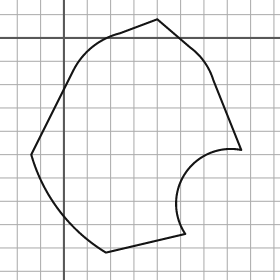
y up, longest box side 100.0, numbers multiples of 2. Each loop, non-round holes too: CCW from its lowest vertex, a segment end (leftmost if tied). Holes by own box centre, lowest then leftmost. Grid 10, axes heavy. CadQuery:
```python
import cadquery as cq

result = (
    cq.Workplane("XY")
    .moveTo(18.0, -92.0)
    .lineTo(52.0, -84.0)
    .threePointArc((52.0, -58.0), (76.0, -48.0))
    .lineTo(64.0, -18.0)
    .threePointArc((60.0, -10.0), (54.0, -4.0))
    .lineTo(40.0, 8.0)
    .lineTo(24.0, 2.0)
    .threePointArc((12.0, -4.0), (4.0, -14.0))
    .lineTo(-14.0, -50.0)
    .threePointArc((-2.0, -74.0), (18.0, -92.0))
    .close()
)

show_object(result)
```